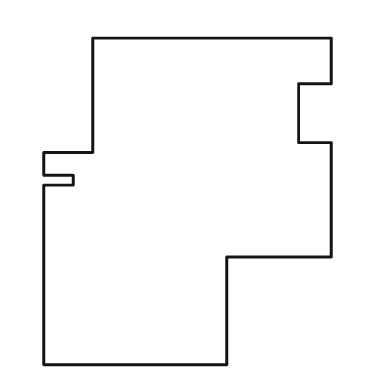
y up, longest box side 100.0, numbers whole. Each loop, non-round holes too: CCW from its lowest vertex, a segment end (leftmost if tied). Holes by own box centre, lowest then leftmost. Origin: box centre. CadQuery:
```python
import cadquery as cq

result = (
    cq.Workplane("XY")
    .moveTo(-44.0, -50.0)
    .lineTo(12.0, -50.0)
    .lineTo(12.0, -17.0)
    .lineTo(44.0, -17.0)
    .lineTo(44.0, 18.0)
    .lineTo(34.0, 18.0)
    .lineTo(34.0, 36.0)
    .lineTo(44.0, 36.0)
    .lineTo(44.0, 50.0)
    .lineTo(-29.0, 50.0)
    .lineTo(-29.0, 15.0)
    .lineTo(-44.0, 15.0)
    .lineTo(-44.0, 8.0)
    .lineTo(-35.0, 8.0)
    .lineTo(-35.0, 5.0)
    .lineTo(-44.0, 5.0)
    .close()
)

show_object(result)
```